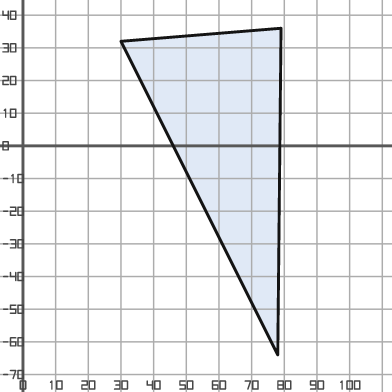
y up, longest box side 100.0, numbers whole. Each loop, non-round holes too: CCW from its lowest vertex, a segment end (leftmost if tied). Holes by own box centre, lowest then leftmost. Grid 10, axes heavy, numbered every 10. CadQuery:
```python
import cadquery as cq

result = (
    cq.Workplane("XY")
    .moveTo(78.0, -64.0)
    .lineTo(79.0, 36.0)
    .lineTo(30.0, 32.0)
    .close()
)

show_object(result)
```